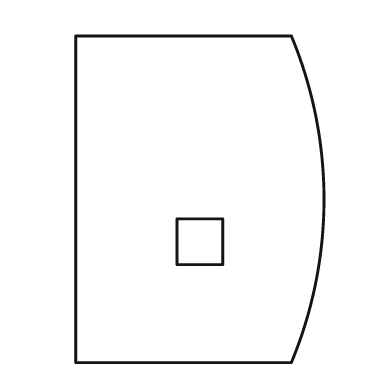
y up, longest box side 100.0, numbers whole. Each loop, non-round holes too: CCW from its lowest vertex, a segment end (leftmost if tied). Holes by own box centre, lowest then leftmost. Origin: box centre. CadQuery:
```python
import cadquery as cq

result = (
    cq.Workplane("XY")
    .moveTo(-38.0, -50.0)
    .lineTo(28.0, -50.0)
    .threePointArc((38.0, 0.0), (28.0, 50.0))
    .lineTo(-38.0, 50.0)
    .close()
    .moveTo(-7.0, -20.0)
    .lineTo(7.0, -20.0)
    .lineTo(7.0, -6.0)
    .lineTo(-7.0, -6.0)
    .close()
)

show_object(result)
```